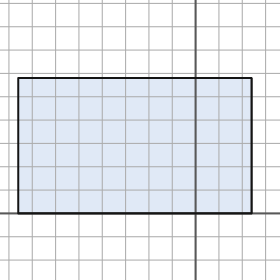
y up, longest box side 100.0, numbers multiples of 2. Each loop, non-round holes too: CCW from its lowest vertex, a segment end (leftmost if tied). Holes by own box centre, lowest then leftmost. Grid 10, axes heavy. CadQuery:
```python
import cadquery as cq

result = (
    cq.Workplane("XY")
    .moveTo(-76.0, 0.0)
    .lineTo(24.0, 0.0)
    .lineTo(24.0, 58.0)
    .lineTo(-76.0, 58.0)
    .close()
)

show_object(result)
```